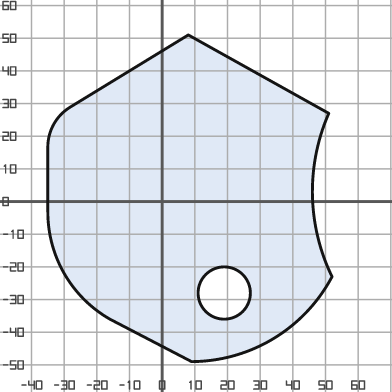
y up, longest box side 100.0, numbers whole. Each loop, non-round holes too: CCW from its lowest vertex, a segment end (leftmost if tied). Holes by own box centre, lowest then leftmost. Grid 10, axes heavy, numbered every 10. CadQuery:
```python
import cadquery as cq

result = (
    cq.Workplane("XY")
    .moveTo(9.0, -49.0)
    .threePointArc((34.0, -42.0), (52.0, -23.0))
    .threePointArc((46.0, 2.0), (51.0, 27.0))
    .lineTo(8.0, 51.0)
    .lineTo(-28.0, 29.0)
    .threePointArc((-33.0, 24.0), (-35.0, 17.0))
    .lineTo(-35.0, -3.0)
    .threePointArc((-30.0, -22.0), (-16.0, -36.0))
    .close()
    .moveTo(19.0, -28.0)
    .circle(8.0)
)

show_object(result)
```